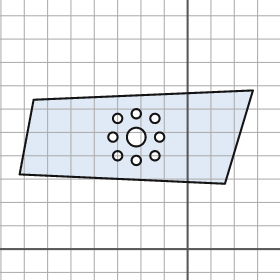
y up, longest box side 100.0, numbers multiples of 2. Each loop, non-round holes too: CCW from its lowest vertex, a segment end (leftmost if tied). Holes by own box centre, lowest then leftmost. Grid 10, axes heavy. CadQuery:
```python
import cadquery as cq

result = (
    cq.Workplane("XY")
    .moveTo(16.0, 28.0)
    .lineTo(28.0, 68.0)
    .lineTo(-66.0, 64.0)
    .lineTo(-72.0, 32.0)
    .close()
    .moveTo(-22.0, 38.0)
    .circle(2.0)
    .moveTo(-30.0, 40.0)
    .circle(2.0)
    .moveTo(-14.0, 40.0)
    .circle(2.0)
    .moveTo(-32.0, 48.0)
    .circle(2.0)
    .moveTo(-22.0, 48.0)
    .circle(4.0)
    .moveTo(-12.0, 48.0)
    .circle(2.0)
    .moveTo(-30.0, 56.0)
    .circle(2.0)
    .moveTo(-14.0, 56.0)
    .circle(2.0)
    .moveTo(-22.0, 58.0)
    .circle(2.0)
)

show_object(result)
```